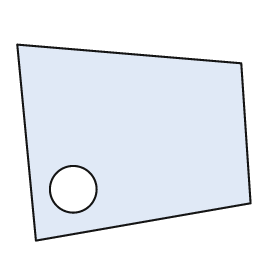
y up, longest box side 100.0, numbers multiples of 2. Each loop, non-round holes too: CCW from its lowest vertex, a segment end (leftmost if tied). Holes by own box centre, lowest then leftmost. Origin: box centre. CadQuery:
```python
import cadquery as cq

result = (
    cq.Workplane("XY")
    .moveTo(-42.0, -42.0)
    .lineTo(50.0, -26.0)
    .lineTo(46.0, 34.0)
    .lineTo(-50.0, 42.0)
    .close()
    .moveTo(-26.0, -20.0)
    .circle(10.0)
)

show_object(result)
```